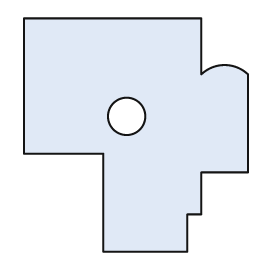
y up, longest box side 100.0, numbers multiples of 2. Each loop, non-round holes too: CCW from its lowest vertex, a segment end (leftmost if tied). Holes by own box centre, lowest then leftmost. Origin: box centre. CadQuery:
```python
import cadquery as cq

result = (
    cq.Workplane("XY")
    .moveTo(-14.0, -50.0)
    .lineTo(22.0, -50.0)
    .lineTo(22.0, -34.0)
    .lineTo(28.0, -34.0)
    .lineTo(28.0, -16.0)
    .lineTo(48.0, -16.0)
    .lineTo(48.0, 26.0)
    .threePointArc((38.0, 30.0), (28.0, 26.0))
    .lineTo(28.0, 50.0)
    .lineTo(-48.0, 50.0)
    .lineTo(-48.0, -8.0)
    .lineTo(-14.0, -8.0)
    .close()
    .moveTo(-4.0, 8.0)
    .circle(8.0)
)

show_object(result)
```